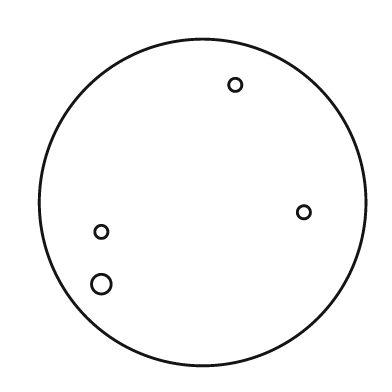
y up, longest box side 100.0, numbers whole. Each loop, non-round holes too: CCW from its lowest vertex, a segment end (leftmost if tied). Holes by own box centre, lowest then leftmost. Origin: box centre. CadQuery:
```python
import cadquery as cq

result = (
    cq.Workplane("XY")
    .moveTo(0.0, 0.0)
    .circle(50.0)
    .moveTo(-31.0, -25.0)
    .circle(3.0)
    .moveTo(-31.0, -9.0)
    .circle(2.0)
    .moveTo(31.0, -3.0)
    .circle(2.0)
    .moveTo(10.0, 36.0)
    .circle(2.0)
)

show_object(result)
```